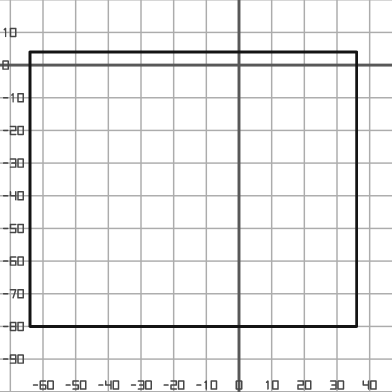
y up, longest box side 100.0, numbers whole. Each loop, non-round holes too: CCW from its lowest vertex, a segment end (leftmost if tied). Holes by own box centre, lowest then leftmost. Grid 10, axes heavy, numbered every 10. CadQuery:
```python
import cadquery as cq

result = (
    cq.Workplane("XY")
    .moveTo(-64.0, -80.0)
    .lineTo(36.0, -80.0)
    .lineTo(36.0, 4.0)
    .lineTo(-64.0, 4.0)
    .close()
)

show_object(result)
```